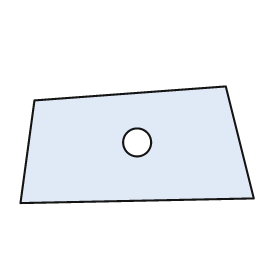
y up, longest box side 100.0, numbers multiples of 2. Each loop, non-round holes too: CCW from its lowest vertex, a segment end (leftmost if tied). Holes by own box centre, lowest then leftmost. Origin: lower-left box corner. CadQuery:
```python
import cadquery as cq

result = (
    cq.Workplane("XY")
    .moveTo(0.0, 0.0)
    .lineTo(100.0, 2.0)
    .lineTo(88.0, 50.0)
    .lineTo(6.0, 44.0)
    .close()
    .moveTo(50.0, 26.0)
    .circle(6.0)
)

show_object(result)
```